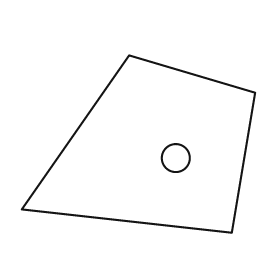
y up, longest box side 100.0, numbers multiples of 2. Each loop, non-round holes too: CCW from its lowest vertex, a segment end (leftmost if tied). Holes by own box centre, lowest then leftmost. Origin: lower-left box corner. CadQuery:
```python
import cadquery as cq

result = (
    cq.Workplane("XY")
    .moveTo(90.0, 0.0)
    .lineTo(100.0, 60.0)
    .lineTo(46.0, 76.0)
    .lineTo(0.0, 10.0)
    .close()
    .moveTo(66.0, 32.0)
    .circle(6.0)
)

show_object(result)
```